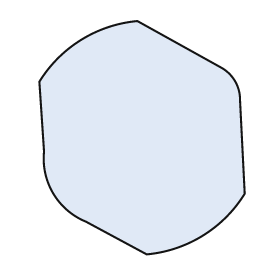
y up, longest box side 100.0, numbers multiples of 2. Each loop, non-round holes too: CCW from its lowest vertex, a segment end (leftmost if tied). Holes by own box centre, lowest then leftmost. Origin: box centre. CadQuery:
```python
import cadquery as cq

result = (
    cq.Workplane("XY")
    .moveTo(2.0, -50.0)
    .threePointArc((26.0, -42.0), (44.0, -24.0))
    .lineTo(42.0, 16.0)
    .threePointArc((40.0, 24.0), (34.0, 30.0))
    .lineTo(-2.0, 50.0)
    .threePointArc((-26.0, 42.0), (-44.0, 24.0))
    .lineTo(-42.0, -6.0)
    .threePointArc((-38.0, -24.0), (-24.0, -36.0))
    .close()
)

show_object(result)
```